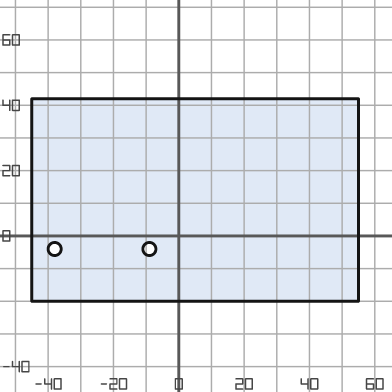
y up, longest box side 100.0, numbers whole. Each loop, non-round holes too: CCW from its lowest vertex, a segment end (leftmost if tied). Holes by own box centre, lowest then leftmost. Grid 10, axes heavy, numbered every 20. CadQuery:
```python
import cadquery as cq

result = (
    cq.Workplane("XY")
    .moveTo(-45.0, -20.0)
    .lineTo(55.0, -20.0)
    .lineTo(55.0, 42.0)
    .lineTo(-45.0, 42.0)
    .close()
    .moveTo(-38.0, -4.0)
    .circle(2.0)
    .moveTo(-9.0, -4.0)
    .circle(2.0)
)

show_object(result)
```